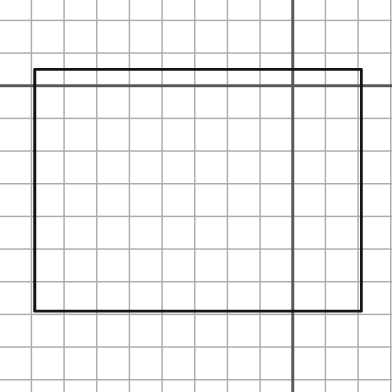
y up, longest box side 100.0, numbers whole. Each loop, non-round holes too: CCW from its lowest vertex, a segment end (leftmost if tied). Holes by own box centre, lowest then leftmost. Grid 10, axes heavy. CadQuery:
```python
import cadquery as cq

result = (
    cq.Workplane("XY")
    .moveTo(-79.0, -69.0)
    .lineTo(21.0, -69.0)
    .lineTo(21.0, 5.0)
    .lineTo(-79.0, 5.0)
    .close()
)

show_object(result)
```